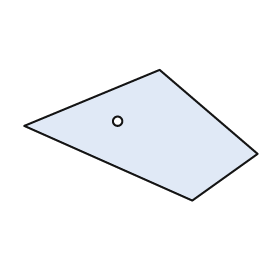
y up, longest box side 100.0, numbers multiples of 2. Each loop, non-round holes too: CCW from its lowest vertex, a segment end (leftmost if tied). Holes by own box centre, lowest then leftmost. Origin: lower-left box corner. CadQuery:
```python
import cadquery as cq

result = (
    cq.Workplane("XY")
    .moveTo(72.0, 0.0)
    .lineTo(100.0, 20.0)
    .lineTo(58.0, 56.0)
    .lineTo(0.0, 32.0)
    .close()
    .moveTo(40.0, 34.0)
    .circle(2.0)
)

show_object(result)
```